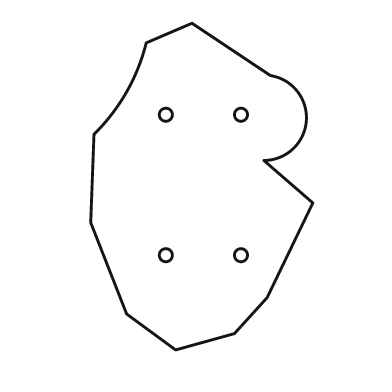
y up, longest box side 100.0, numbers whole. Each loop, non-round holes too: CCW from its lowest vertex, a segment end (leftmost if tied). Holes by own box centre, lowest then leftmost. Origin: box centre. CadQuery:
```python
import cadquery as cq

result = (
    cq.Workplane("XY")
    .moveTo(-8.0, -50.0)
    .lineTo(10.0, -45.0)
    .lineTo(20.0, -34.0)
    .lineTo(34.0, -5.0)
    .lineTo(19.0, 8.0)
    .threePointArc((32.0, 20.0), (21.0, 34.0))
    .lineTo(-3.0, 50.0)
    .lineTo(-17.0, 44.0)
    .threePointArc((-23.0, 29.0), (-33.0, 16.0))
    .lineTo(-34.0, -11.0)
    .lineTo(-23.0, -39.0)
    .close()
    .moveTo(-11.0, -21.0)
    .circle(2.0)
    .moveTo(12.0, -21.0)
    .circle(2.0)
    .moveTo(-11.0, 22.0)
    .circle(2.0)
    .moveTo(12.0, 22.0)
    .circle(2.0)
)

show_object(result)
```